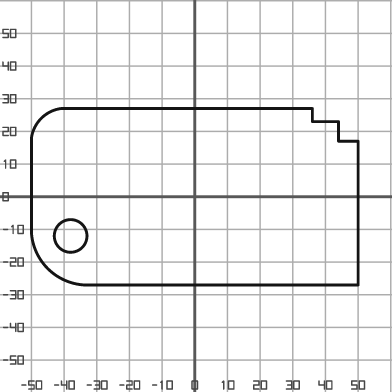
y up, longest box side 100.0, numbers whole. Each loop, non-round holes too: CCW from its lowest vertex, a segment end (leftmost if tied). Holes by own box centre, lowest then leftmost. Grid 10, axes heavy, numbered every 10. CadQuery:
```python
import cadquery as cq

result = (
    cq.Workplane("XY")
    .moveTo(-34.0, -27.0)
    .lineTo(50.0, -27.0)
    .lineTo(50.0, 17.0)
    .lineTo(44.0, 17.0)
    .lineTo(44.0, 23.0)
    .lineTo(36.0, 23.0)
    .lineTo(36.0, 27.0)
    .lineTo(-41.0, 27.0)
    .threePointArc((-47.0, 24.0), (-50.0, 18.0))
    .lineTo(-50.0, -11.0)
    .threePointArc((-45.0, -22.0), (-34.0, -27.0))
    .close()
    .moveTo(-38.0, -12.0)
    .circle(5.0)
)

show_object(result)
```